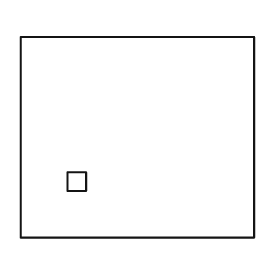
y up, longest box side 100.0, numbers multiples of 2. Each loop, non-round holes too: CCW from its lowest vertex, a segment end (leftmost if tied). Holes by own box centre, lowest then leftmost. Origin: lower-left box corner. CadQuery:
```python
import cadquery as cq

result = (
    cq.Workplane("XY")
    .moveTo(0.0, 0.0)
    .lineTo(100.0, 0.0)
    .lineTo(100.0, 86.0)
    .lineTo(0.0, 86.0)
    .close()
    .moveTo(20.0, 20.0)
    .lineTo(28.0, 20.0)
    .lineTo(28.0, 28.0)
    .lineTo(20.0, 28.0)
    .close()
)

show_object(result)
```